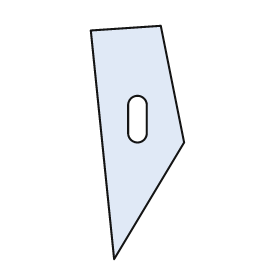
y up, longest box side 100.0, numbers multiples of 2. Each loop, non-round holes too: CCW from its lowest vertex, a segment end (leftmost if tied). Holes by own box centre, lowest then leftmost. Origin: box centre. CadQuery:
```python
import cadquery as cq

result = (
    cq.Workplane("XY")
    .moveTo(-10.0, -50.0)
    .lineTo(20.0, 0.0)
    .lineTo(10.0, 50.0)
    .lineTo(-20.0, 48.0)
    .close()
    .moveTo(-4.0, 4.0)
    .threePointArc((0.0, 0.0), (4.0, 4.0))
    .lineTo(4.0, 16.0)
    .threePointArc((0.0, 20.0), (-4.0, 16.0))
    .close()
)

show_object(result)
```